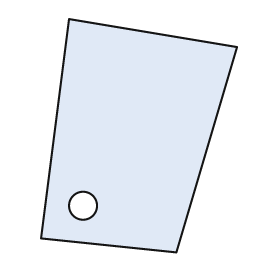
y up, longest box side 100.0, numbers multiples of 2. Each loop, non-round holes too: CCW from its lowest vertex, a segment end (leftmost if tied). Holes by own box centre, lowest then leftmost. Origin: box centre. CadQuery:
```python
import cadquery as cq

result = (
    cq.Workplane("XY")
    .moveTo(16.0, -50.0)
    .lineTo(42.0, 38.0)
    .lineTo(-30.0, 50.0)
    .lineTo(-42.0, -44.0)
    .close()
    .moveTo(-24.0, -30.0)
    .circle(6.0)
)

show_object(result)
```